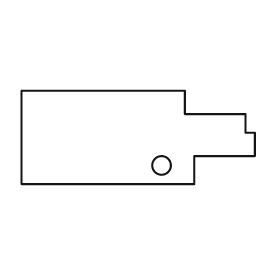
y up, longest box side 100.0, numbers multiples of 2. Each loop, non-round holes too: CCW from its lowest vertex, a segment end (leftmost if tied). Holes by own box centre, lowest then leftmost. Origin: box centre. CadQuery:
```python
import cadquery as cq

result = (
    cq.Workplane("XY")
    .moveTo(-50.0, -20.0)
    .lineTo(24.0, -20.0)
    .lineTo(24.0, -8.0)
    .lineTo(50.0, -8.0)
    .lineTo(50.0, 2.0)
    .lineTo(46.0, 2.0)
    .lineTo(46.0, 10.0)
    .lineTo(20.0, 10.0)
    .lineTo(20.0, 20.0)
    .lineTo(-50.0, 20.0)
    .close()
    .moveTo(10.0, -12.0)
    .circle(4.0)
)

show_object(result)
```